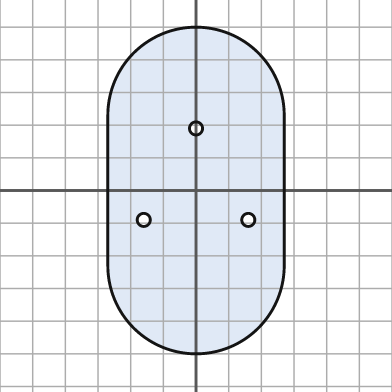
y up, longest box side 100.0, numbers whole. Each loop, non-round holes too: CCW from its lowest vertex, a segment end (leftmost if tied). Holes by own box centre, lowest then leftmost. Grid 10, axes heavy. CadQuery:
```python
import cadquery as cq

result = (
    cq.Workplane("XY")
    .moveTo(-27.0, -23.0)
    .threePointArc((0.0, -50.0), (27.0, -23.0))
    .lineTo(27.0, 23.0)
    .threePointArc((0.0, 50.0), (-27.0, 23.0))
    .close()
    .moveTo(-16.0, -9.0)
    .circle(2.0)
    .moveTo(16.0, -9.0)
    .circle(2.0)
    .moveTo(0.0, 19.0)
    .circle(2.0)
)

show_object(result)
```